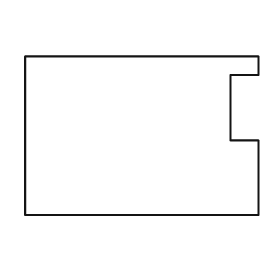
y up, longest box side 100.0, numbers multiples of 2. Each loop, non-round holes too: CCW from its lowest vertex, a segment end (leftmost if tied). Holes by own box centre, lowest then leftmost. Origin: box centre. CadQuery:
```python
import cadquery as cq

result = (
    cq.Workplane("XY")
    .moveTo(-50.0, -34.0)
    .lineTo(50.0, -34.0)
    .lineTo(50.0, -2.0)
    .lineTo(38.0, -2.0)
    .lineTo(38.0, 26.0)
    .lineTo(50.0, 26.0)
    .lineTo(50.0, 34.0)
    .lineTo(-50.0, 34.0)
    .close()
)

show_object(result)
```